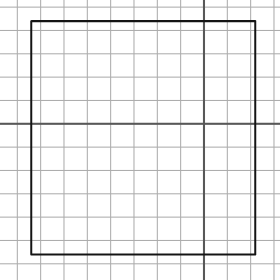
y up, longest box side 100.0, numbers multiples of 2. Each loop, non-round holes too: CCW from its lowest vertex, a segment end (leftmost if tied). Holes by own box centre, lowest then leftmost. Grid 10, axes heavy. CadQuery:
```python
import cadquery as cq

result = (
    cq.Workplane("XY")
    .moveTo(-74.0, -56.0)
    .lineTo(22.0, -56.0)
    .lineTo(22.0, 44.0)
    .lineTo(-74.0, 44.0)
    .close()
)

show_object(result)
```